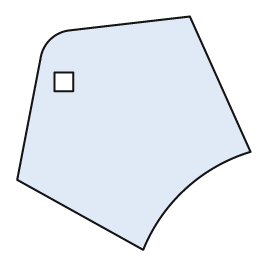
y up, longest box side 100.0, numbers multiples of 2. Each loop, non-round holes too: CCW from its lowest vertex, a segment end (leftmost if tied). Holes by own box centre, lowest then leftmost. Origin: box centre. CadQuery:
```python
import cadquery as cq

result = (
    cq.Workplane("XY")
    .moveTo(4.0, -50.0)
    .threePointArc((22.0, -24.0), (50.0, -8.0))
    .lineTo(24.0, 50.0)
    .lineTo(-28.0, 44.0)
    .threePointArc((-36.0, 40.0), (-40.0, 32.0))
    .lineTo(-50.0, -20.0)
    .close()
    .moveTo(-34.0, 18.0)
    .lineTo(-26.0, 18.0)
    .lineTo(-26.0, 26.0)
    .lineTo(-34.0, 26.0)
    .close()
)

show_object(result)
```